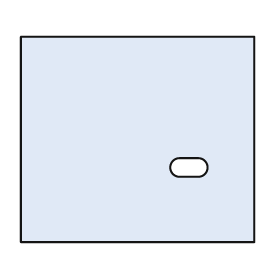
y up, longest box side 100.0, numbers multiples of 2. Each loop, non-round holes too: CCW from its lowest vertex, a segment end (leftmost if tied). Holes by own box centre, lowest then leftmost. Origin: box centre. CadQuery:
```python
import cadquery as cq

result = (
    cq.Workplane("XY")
    .moveTo(-50.0, -44.0)
    .lineTo(50.0, -44.0)
    .lineTo(50.0, 44.0)
    .lineTo(-50.0, 44.0)
    .close()
    .moveTo(18.0, -16.0)
    .lineTo(26.0, -16.0)
    .threePointArc((30.0, -12.0), (26.0, -8.0))
    .lineTo(18.0, -8.0)
    .threePointArc((14.0, -12.0), (18.0, -16.0))
    .close()
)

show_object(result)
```